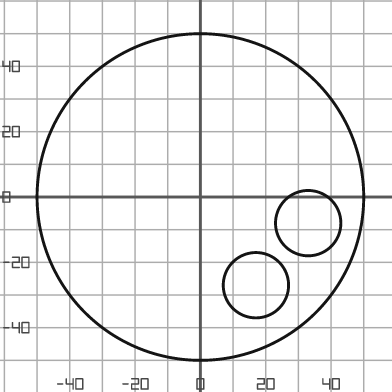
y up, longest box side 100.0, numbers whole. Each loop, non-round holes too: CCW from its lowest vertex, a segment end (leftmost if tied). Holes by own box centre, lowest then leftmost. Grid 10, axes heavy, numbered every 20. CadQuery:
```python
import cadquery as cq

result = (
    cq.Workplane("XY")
    .moveTo(0.0, 0.0)
    .circle(50.0)
    .moveTo(17.0, -27.0)
    .circle(10.0)
    .moveTo(33.0, -8.0)
    .circle(10.0)
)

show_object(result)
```